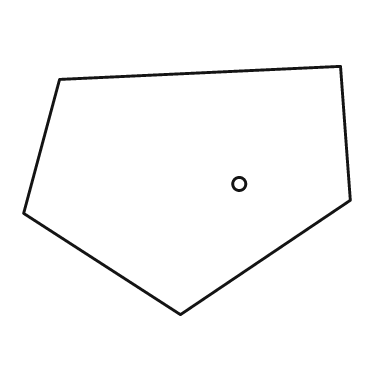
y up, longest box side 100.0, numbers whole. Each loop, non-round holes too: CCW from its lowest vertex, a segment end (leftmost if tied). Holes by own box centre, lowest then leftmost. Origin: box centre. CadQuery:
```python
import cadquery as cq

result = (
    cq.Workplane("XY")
    .moveTo(-2.0, -38.0)
    .lineTo(50.0, -3.0)
    .lineTo(47.0, 38.0)
    .lineTo(-39.0, 34.0)
    .lineTo(-50.0, -7.0)
    .close()
    .moveTo(16.0, 2.0)
    .circle(2.0)
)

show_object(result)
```